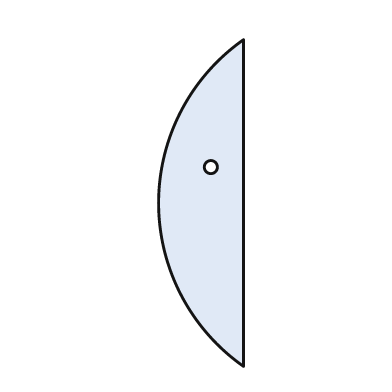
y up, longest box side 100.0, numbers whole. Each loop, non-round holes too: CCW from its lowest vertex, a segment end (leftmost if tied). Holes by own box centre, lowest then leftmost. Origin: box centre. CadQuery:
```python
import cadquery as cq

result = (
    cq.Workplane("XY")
    .moveTo(13.0, -50.0)
    .lineTo(13.0, 50.0)
    .threePointArc((-13.0, 0.0), (13.0, -50.0))
    .close()
    .moveTo(3.0, 11.0)
    .circle(2.0)
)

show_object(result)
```